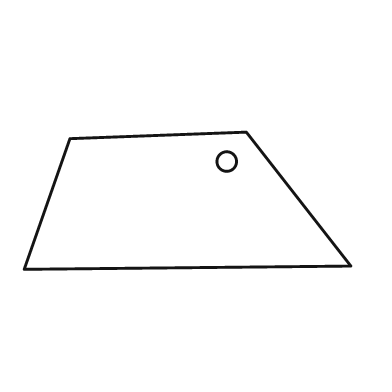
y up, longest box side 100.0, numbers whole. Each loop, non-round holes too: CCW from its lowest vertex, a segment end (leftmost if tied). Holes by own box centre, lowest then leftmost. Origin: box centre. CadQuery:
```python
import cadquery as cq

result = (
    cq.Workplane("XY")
    .moveTo(-50.0, -21.0)
    .lineTo(50.0, -20.0)
    .lineTo(18.0, 21.0)
    .lineTo(-36.0, 19.0)
    .close()
    .moveTo(12.0, 12.0)
    .circle(3.0)
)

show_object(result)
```